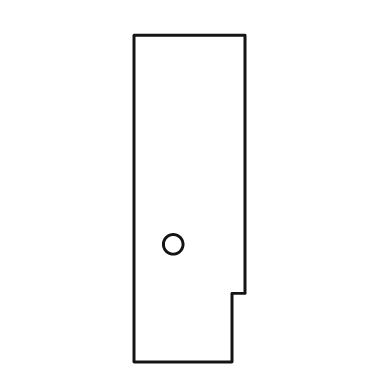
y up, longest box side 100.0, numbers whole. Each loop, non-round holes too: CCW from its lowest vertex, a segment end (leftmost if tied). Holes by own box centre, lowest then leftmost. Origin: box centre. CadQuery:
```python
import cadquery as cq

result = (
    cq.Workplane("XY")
    .moveTo(-17.0, -50.0)
    .lineTo(13.0, -50.0)
    .lineTo(13.0, -29.0)
    .lineTo(17.0, -29.0)
    .lineTo(17.0, 50.0)
    .lineTo(-17.0, 50.0)
    .close()
    .moveTo(-5.0, -14.0)
    .circle(3.0)
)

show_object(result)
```